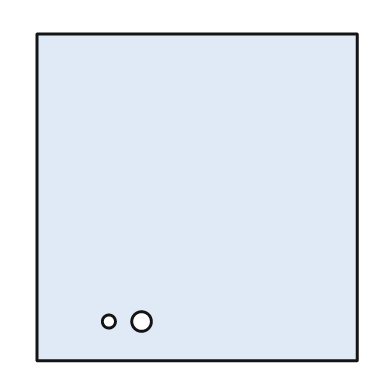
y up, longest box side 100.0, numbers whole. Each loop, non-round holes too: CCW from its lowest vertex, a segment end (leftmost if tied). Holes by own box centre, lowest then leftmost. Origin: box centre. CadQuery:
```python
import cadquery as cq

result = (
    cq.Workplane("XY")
    .moveTo(-49.0, -50.0)
    .lineTo(49.0, -50.0)
    .lineTo(49.0, 50.0)
    .lineTo(-49.0, 50.0)
    .close()
    .moveTo(-27.0, -38.0)
    .circle(2.0)
    .moveTo(-17.0, -38.0)
    .circle(3.0)
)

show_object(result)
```